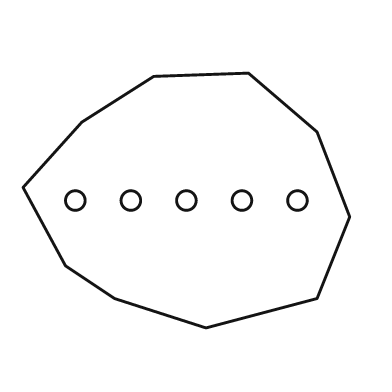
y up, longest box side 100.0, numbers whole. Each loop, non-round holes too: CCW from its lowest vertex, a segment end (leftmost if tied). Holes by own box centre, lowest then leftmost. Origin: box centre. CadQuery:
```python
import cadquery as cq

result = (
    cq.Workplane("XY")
    .moveTo(6.0, -39.0)
    .lineTo(40.0, -30.0)
    .lineTo(50.0, -5.0)
    .lineTo(40.0, 21.0)
    .lineTo(19.0, 39.0)
    .lineTo(-10.0, 38.0)
    .lineTo(-32.0, 24.0)
    .lineTo(-50.0, 4.0)
    .lineTo(-37.0, -20.0)
    .lineTo(-22.0, -30.0)
    .close()
    .moveTo(-34.0, 0.0)
    .circle(3.0)
    .moveTo(-17.0, 0.0)
    .circle(3.0)
    .moveTo(0.0, 0.0)
    .circle(3.0)
    .moveTo(17.0, 0.0)
    .circle(3.0)
    .moveTo(34.0, 0.0)
    .circle(3.0)
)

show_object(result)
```